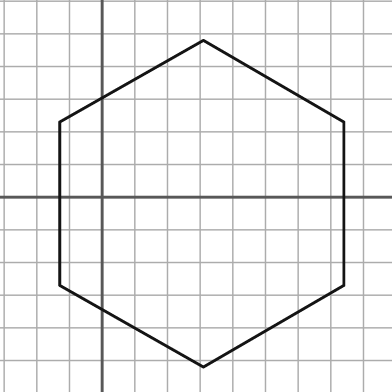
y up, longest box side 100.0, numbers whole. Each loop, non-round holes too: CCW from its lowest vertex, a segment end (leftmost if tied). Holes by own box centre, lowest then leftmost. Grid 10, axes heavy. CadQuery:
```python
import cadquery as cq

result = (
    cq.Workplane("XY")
    .moveTo(31.0, -52.0)
    .lineTo(74.0, -27.0)
    .lineTo(74.0, 23.0)
    .lineTo(31.0, 48.0)
    .lineTo(-13.0, 23.0)
    .lineTo(-13.0, -27.0)
    .close()
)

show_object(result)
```